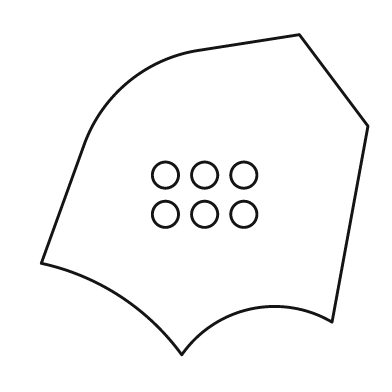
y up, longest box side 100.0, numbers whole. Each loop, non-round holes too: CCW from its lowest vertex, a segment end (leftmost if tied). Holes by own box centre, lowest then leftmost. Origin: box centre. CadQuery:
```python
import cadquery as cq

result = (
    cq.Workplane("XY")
    .moveTo(-7.0, -49.0)
    .threePointArc((14.0, -35.0), (39.0, -39.0))
    .lineTo(50.0, 21.0)
    .lineTo(29.0, 49.0)
    .lineTo(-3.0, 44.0)
    .threePointArc((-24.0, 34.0), (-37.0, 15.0))
    .lineTo(-50.0, -21.0)
    .threePointArc((-26.0, -31.0), (-7.0, -49.0))
    .close()
    .moveTo(-12.0, -6.0)
    .circle(4.0)
    .moveTo(0.0, -6.0)
    .circle(4.0)
    .moveTo(12.0, -6.0)
    .circle(4.0)
    .moveTo(-12.0, 6.0)
    .circle(4.0)
    .moveTo(0.0, 6.0)
    .circle(4.0)
    .moveTo(12.0, 6.0)
    .circle(4.0)
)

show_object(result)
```